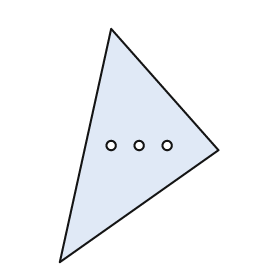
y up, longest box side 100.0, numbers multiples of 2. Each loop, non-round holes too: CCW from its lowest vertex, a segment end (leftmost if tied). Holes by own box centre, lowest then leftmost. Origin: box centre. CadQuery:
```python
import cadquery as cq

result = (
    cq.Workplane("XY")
    .moveTo(-34.0, -50.0)
    .lineTo(34.0, -2.0)
    .lineTo(-12.0, 50.0)
    .close()
    .moveTo(-12.0, 0.0)
    .circle(2.0)
    .moveTo(0.0, 0.0)
    .circle(2.0)
    .moveTo(12.0, 0.0)
    .circle(2.0)
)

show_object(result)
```